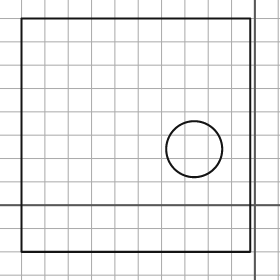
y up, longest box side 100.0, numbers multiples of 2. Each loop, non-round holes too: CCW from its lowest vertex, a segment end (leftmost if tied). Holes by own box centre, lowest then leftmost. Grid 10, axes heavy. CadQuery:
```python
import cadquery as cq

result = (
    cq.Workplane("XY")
    .moveTo(-100.0, -20.0)
    .lineTo(-2.0, -20.0)
    .lineTo(-2.0, 80.0)
    .lineTo(-100.0, 80.0)
    .close()
    .moveTo(-26.0, 24.0)
    .circle(12.0)
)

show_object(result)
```